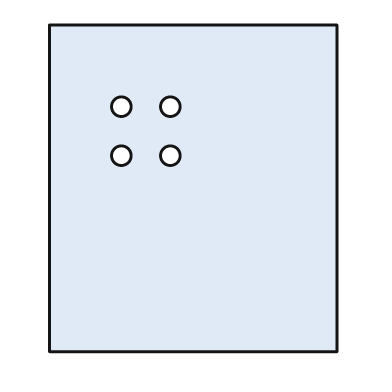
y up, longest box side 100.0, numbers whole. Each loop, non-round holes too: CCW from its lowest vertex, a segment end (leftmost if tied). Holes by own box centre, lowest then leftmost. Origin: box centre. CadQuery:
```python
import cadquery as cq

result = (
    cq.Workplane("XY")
    .moveTo(-44.0, -50.0)
    .lineTo(44.0, -50.0)
    .lineTo(44.0, 50.0)
    .lineTo(-44.0, 50.0)
    .close()
    .moveTo(-22.0, 10.0)
    .circle(3.0)
    .moveTo(-7.0, 10.0)
    .circle(3.0)
    .moveTo(-22.0, 25.0)
    .circle(3.0)
    .moveTo(-7.0, 25.0)
    .circle(3.0)
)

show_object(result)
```